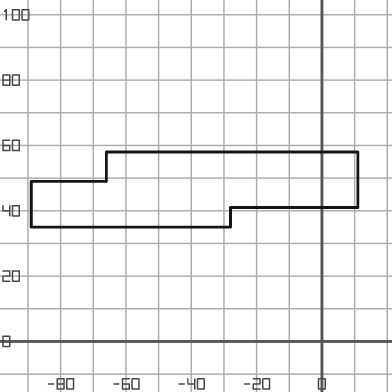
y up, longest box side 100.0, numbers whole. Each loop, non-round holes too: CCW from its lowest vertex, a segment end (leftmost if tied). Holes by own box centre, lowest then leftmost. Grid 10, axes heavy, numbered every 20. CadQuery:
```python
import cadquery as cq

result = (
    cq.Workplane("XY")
    .moveTo(-89.0, 35.0)
    .lineTo(-28.0, 35.0)
    .lineTo(-28.0, 41.0)
    .lineTo(11.0, 41.0)
    .lineTo(11.0, 58.0)
    .lineTo(-66.0, 58.0)
    .lineTo(-66.0, 49.0)
    .lineTo(-89.0, 49.0)
    .close()
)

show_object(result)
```